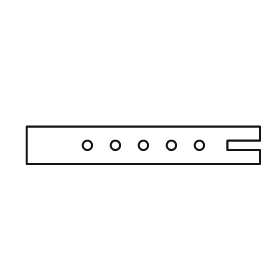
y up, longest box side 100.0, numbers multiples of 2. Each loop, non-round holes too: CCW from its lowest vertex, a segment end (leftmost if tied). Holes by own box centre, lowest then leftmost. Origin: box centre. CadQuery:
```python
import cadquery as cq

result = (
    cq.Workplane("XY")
    .moveTo(-50.0, -8.0)
    .lineTo(50.0, -8.0)
    .lineTo(50.0, -2.0)
    .lineTo(36.0, -2.0)
    .lineTo(36.0, 2.0)
    .lineTo(50.0, 2.0)
    .lineTo(50.0, 8.0)
    .lineTo(-50.0, 8.0)
    .close()
    .moveTo(-24.0, 0.0)
    .circle(2.0)
    .moveTo(-12.0, 0.0)
    .circle(2.0)
    .moveTo(0.0, 0.0)
    .circle(2.0)
    .moveTo(12.0, 0.0)
    .circle(2.0)
    .moveTo(24.0, 0.0)
    .circle(2.0)
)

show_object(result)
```